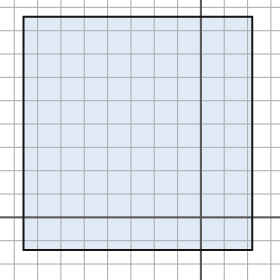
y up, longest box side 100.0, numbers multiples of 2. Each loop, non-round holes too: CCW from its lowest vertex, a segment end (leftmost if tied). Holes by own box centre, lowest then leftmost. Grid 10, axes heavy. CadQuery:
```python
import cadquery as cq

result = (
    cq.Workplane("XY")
    .moveTo(-76.0, -14.0)
    .lineTo(22.0, -14.0)
    .lineTo(22.0, 86.0)
    .lineTo(-76.0, 86.0)
    .close()
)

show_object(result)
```